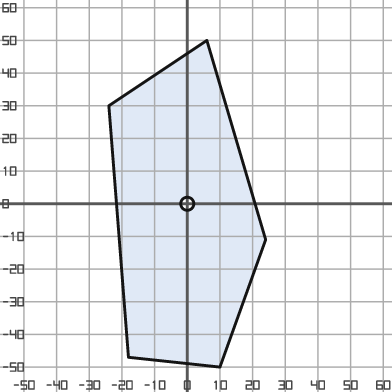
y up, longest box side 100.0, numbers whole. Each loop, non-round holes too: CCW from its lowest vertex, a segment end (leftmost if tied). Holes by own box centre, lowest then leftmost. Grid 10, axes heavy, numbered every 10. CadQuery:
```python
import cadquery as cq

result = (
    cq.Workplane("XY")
    .moveTo(10.0, -50.0)
    .lineTo(24.0, -11.0)
    .lineTo(6.0, 50.0)
    .lineTo(-24.0, 30.0)
    .lineTo(-18.0, -47.0)
    .close()
    .moveTo(0.0, 0.0)
    .circle(2.0)
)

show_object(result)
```